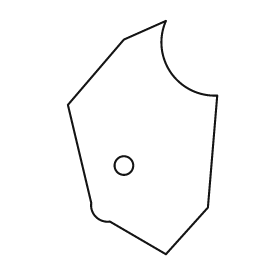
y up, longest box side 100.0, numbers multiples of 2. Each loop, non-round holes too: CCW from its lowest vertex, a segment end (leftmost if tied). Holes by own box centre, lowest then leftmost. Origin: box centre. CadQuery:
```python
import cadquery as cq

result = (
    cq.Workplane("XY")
    .moveTo(10.0, -50.0)
    .lineTo(28.0, -30.0)
    .lineTo(32.0, 18.0)
    .threePointArc((12.0, 28.0), (10.0, 50.0))
    .lineTo(-8.0, 42.0)
    .lineTo(-32.0, 14.0)
    .lineTo(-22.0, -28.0)
    .threePointArc((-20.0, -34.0), (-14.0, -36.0))
    .close()
    .moveTo(-8.0, -12.0)
    .circle(4.0)
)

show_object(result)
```